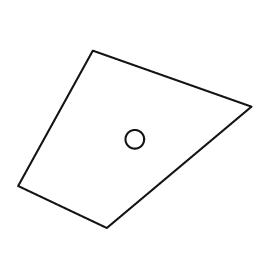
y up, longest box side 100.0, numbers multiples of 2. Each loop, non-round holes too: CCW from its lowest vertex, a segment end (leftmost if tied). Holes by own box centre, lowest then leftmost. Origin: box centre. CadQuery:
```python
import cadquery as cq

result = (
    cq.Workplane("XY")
    .moveTo(-12.0, -38.0)
    .lineTo(50.0, 14.0)
    .lineTo(-18.0, 38.0)
    .lineTo(-50.0, -20.0)
    .close()
    .moveTo(0.0, 0.0)
    .circle(4.0)
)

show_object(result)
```